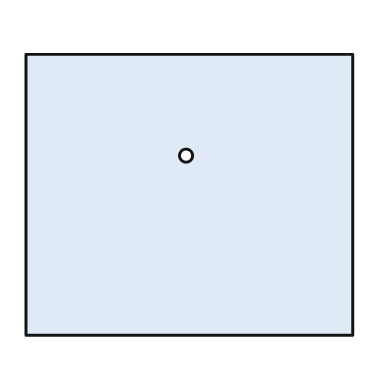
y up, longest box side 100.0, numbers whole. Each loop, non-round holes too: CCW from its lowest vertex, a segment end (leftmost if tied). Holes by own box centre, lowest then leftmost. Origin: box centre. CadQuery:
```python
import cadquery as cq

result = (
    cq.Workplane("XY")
    .moveTo(-50.0, -43.0)
    .lineTo(50.0, -43.0)
    .lineTo(50.0, 43.0)
    .lineTo(-50.0, 43.0)
    .close()
    .moveTo(-1.0, 12.0)
    .circle(2.0)
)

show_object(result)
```